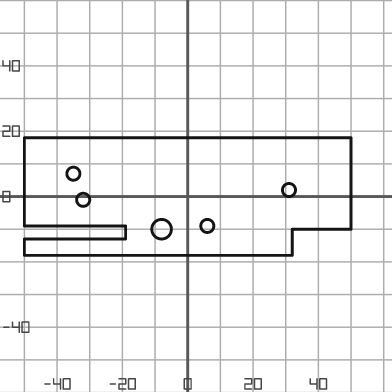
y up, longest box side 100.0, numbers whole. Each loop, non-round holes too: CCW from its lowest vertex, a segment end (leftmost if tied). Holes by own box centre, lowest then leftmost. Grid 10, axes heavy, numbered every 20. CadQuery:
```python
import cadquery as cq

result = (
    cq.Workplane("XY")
    .moveTo(-50.0, -18.0)
    .lineTo(32.0, -18.0)
    .lineTo(32.0, -10.0)
    .lineTo(50.0, -10.0)
    .lineTo(50.0, 18.0)
    .lineTo(-50.0, 18.0)
    .lineTo(-50.0, -9.0)
    .lineTo(-19.0, -9.0)
    .lineTo(-19.0, -13.0)
    .lineTo(-50.0, -13.0)
    .close()
    .moveTo(-8.0, -10.0)
    .circle(3.0)
    .moveTo(6.0, -9.0)
    .circle(2.0)
    .moveTo(-32.0, -1.0)
    .circle(2.0)
    .moveTo(31.0, 2.0)
    .circle(2.0)
    .moveTo(-35.0, 7.0)
    .circle(2.0)
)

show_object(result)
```